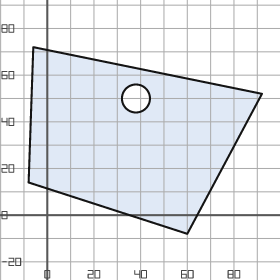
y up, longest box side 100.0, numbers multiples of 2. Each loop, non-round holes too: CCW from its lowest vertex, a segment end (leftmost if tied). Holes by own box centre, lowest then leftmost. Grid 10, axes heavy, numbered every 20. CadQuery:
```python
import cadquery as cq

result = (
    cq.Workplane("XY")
    .moveTo(60.0, -8.0)
    .lineTo(92.0, 52.0)
    .lineTo(-6.0, 72.0)
    .lineTo(-8.0, 14.0)
    .close()
    .moveTo(38.0, 50.0)
    .circle(6.0)
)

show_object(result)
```